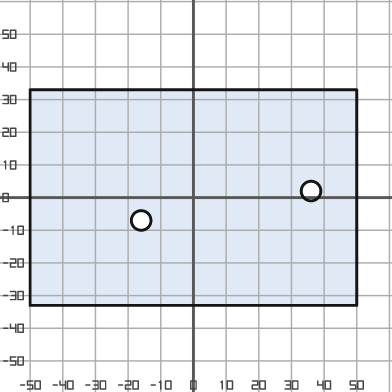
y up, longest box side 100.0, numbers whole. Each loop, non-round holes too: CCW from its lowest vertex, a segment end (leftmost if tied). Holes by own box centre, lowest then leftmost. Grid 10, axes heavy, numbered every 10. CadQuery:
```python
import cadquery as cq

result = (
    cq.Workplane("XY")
    .moveTo(-50.0, -33.0)
    .lineTo(50.0, -33.0)
    .lineTo(50.0, 33.0)
    .lineTo(-50.0, 33.0)
    .close()
    .moveTo(-16.0, -7.0)
    .circle(3.0)
    .moveTo(36.0, 2.0)
    .circle(3.0)
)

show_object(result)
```